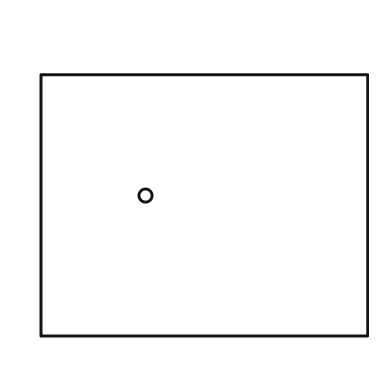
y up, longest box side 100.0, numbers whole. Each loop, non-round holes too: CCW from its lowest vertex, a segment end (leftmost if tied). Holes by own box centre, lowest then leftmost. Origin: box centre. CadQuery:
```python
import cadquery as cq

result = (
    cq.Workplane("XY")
    .moveTo(-50.0, -40.0)
    .lineTo(50.0, -40.0)
    .lineTo(50.0, 40.0)
    .lineTo(-50.0, 40.0)
    .close()
    .moveTo(-18.0, 3.0)
    .circle(2.0)
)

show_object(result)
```